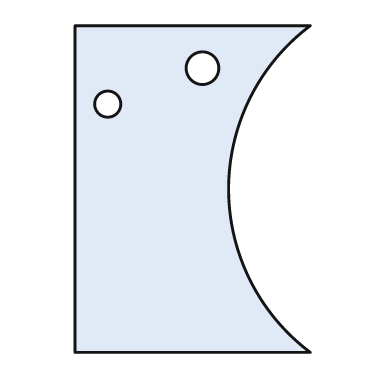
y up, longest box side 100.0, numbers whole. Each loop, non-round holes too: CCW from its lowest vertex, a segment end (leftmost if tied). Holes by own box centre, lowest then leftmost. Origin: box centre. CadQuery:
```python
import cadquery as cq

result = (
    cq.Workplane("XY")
    .moveTo(-36.0, -50.0)
    .lineTo(36.0, -50.0)
    .threePointArc((11.0, 0.0), (36.0, 50.0))
    .lineTo(-36.0, 50.0)
    .close()
    .moveTo(-26.0, 26.0)
    .circle(4.0)
    .moveTo(3.0, 37.0)
    .circle(5.0)
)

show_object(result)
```